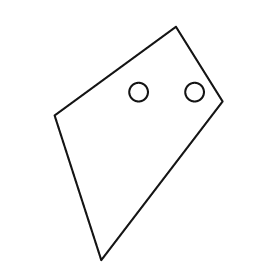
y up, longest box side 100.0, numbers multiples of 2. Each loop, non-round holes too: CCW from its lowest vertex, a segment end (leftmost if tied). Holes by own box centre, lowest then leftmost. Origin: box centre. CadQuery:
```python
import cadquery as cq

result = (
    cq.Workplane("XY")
    .moveTo(-16.0, -50.0)
    .lineTo(36.0, 18.0)
    .lineTo(16.0, 50.0)
    .lineTo(-36.0, 12.0)
    .close()
    .moveTo(0.0, 22.0)
    .circle(4.0)
    .moveTo(24.0, 22.0)
    .circle(4.0)
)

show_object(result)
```